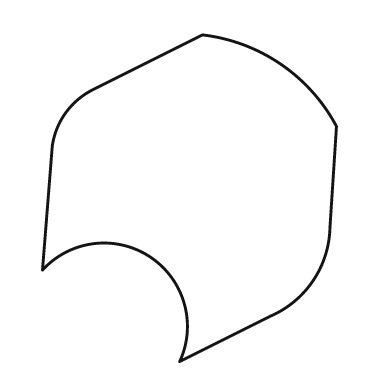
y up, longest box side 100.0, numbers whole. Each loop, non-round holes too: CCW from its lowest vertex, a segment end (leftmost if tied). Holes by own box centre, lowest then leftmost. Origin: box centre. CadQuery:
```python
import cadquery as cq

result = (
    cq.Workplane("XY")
    .moveTo(-3.0, -50.0)
    .lineTo(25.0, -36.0)
    .threePointArc((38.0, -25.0), (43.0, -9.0))
    .lineTo(45.0, 22.0)
    .threePointArc((28.0, 41.0), (4.0, 50.0))
    .lineTo(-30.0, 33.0)
    .threePointArc((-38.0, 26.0), (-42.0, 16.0))
    .lineTo(-45.0, -22.0)
    .threePointArc((-12.0, -18.0), (-3.0, -50.0))
    .close()
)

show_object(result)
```